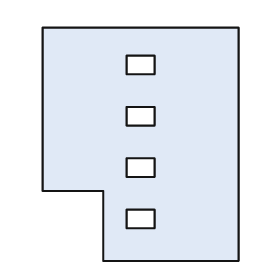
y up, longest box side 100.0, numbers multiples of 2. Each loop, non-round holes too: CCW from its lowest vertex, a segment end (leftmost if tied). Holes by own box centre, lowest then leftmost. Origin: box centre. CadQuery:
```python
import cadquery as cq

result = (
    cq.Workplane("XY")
    .moveTo(-16.0, -50.0)
    .lineTo(42.0, -50.0)
    .lineTo(42.0, 50.0)
    .lineTo(-42.0, 50.0)
    .lineTo(-42.0, -20.0)
    .lineTo(-16.0, -20.0)
    .close()
    .moveTo(-6.0, -36.0)
    .lineTo(6.0, -36.0)
    .lineTo(6.0, -28.0)
    .lineTo(-6.0, -28.0)
    .close()
    .moveTo(-6.0, -14.0)
    .lineTo(6.0, -14.0)
    .lineTo(6.0, -6.0)
    .lineTo(-6.0, -6.0)
    .close()
    .moveTo(-6.0, 8.0)
    .lineTo(6.0, 8.0)
    .lineTo(6.0, 16.0)
    .lineTo(-6.0, 16.0)
    .close()
    .moveTo(-6.0, 30.0)
    .lineTo(6.0, 30.0)
    .lineTo(6.0, 38.0)
    .lineTo(-6.0, 38.0)
    .close()
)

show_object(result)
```